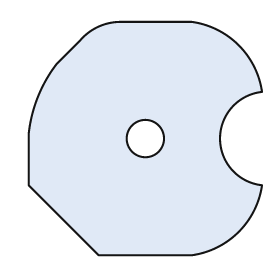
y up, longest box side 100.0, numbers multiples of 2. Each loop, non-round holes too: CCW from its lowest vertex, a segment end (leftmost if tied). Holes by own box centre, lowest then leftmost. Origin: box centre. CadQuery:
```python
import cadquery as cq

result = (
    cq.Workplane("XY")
    .moveTo(-20.0, -50.0)
    .lineTo(20.0, -50.0)
    .threePointArc((40.0, -40.0), (50.0, -20.0))
    .threePointArc((32.0, 0.0), (50.0, 20.0))
    .threePointArc((40.0, 40.0), (20.0, 50.0))
    .lineTo(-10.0, 50.0)
    .threePointArc((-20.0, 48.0), (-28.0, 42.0))
    .lineTo(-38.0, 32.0)
    .threePointArc((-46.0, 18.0), (-50.0, 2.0))
    .lineTo(-50.0, -20.0)
    .close()
    .moveTo(0.0, 0.0)
    .circle(8.0)
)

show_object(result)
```